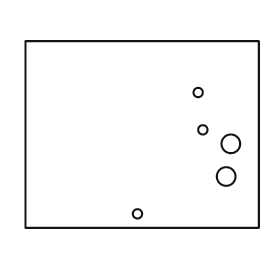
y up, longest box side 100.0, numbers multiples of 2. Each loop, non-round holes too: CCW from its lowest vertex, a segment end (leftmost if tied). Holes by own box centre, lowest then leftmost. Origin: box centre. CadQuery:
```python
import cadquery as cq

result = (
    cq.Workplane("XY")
    .moveTo(-50.0, -40.0)
    .lineTo(50.0, -40.0)
    .lineTo(50.0, 40.0)
    .lineTo(-50.0, 40.0)
    .close()
    .moveTo(-2.0, -34.0)
    .circle(2.0)
    .moveTo(36.0, -18.0)
    .circle(4.0)
    .moveTo(38.0, -4.0)
    .circle(4.0)
    .moveTo(26.0, 2.0)
    .circle(2.0)
    .moveTo(24.0, 18.0)
    .circle(2.0)
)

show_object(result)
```